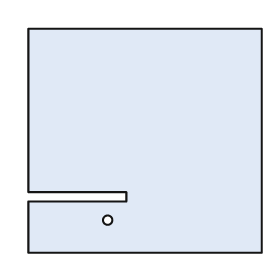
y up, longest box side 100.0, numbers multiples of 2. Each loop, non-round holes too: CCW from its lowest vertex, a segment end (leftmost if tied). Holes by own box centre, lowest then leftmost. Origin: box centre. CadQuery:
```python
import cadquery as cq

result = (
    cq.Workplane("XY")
    .moveTo(-50.0, -48.0)
    .lineTo(50.0, -48.0)
    .lineTo(50.0, 48.0)
    .lineTo(-50.0, 48.0)
    .lineTo(-50.0, -22.0)
    .lineTo(-8.0, -22.0)
    .lineTo(-8.0, -26.0)
    .lineTo(-50.0, -26.0)
    .close()
    .moveTo(-16.0, -34.0)
    .circle(2.0)
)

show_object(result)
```